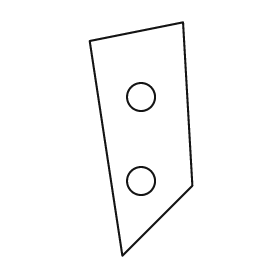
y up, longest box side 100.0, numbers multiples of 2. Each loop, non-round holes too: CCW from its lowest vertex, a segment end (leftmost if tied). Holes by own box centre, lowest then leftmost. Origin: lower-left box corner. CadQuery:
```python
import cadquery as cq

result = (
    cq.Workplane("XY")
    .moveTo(14.0, 0.0)
    .lineTo(44.0, 30.0)
    .lineTo(40.0, 100.0)
    .lineTo(0.0, 92.0)
    .close()
    .moveTo(22.0, 32.0)
    .circle(6.0)
    .moveTo(22.0, 68.0)
    .circle(6.0)
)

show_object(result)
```